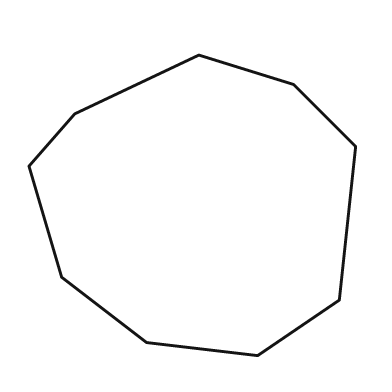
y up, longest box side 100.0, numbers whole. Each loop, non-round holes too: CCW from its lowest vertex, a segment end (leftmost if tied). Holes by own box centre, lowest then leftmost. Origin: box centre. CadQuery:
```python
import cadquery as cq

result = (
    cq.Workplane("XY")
    .moveTo(20.0, -46.0)
    .lineTo(45.0, -29.0)
    .lineTo(50.0, 18.0)
    .lineTo(31.0, 37.0)
    .lineTo(2.0, 46.0)
    .lineTo(-36.0, 28.0)
    .lineTo(-50.0, 12.0)
    .lineTo(-40.0, -22.0)
    .lineTo(-14.0, -42.0)
    .close()
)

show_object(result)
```